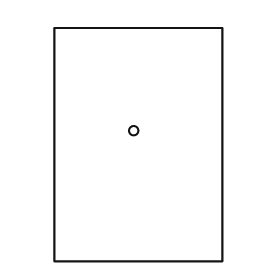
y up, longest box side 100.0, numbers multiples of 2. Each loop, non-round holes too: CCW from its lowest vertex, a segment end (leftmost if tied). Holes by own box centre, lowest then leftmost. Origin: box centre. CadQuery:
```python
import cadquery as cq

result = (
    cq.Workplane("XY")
    .moveTo(-36.0, -50.0)
    .lineTo(36.0, -50.0)
    .lineTo(36.0, 50.0)
    .lineTo(-36.0, 50.0)
    .close()
    .moveTo(-2.0, 6.0)
    .circle(2.0)
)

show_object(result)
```